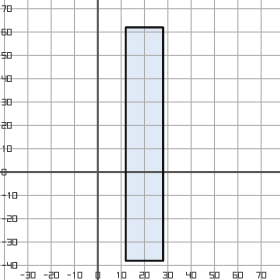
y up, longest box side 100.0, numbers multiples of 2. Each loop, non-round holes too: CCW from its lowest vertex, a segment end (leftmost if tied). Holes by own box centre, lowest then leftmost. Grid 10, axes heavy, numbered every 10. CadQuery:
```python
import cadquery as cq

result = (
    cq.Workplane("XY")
    .moveTo(12.0, -38.0)
    .lineTo(28.0, -38.0)
    .lineTo(28.0, 62.0)
    .lineTo(12.0, 62.0)
    .close()
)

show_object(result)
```